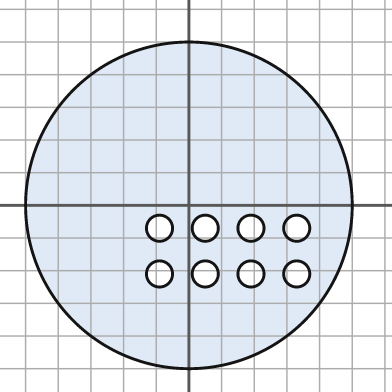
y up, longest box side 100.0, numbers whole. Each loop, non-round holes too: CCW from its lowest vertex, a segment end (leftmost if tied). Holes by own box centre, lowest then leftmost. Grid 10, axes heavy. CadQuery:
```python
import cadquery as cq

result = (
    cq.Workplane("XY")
    .moveTo(0.0, 0.0)
    .circle(50.0)
    .moveTo(-9.0, -21.0)
    .circle(4.0)
    .moveTo(5.0, -21.0)
    .circle(4.0)
    .moveTo(19.0, -21.0)
    .circle(4.0)
    .moveTo(33.0, -21.0)
    .circle(4.0)
    .moveTo(-9.0, -7.0)
    .circle(4.0)
    .moveTo(5.0, -7.0)
    .circle(4.0)
    .moveTo(19.0, -7.0)
    .circle(4.0)
    .moveTo(33.0, -7.0)
    .circle(4.0)
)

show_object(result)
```